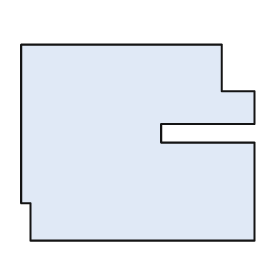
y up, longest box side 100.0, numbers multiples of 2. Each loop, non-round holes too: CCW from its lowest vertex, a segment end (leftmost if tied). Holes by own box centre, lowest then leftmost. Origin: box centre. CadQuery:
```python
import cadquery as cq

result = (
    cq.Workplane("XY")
    .moveTo(-46.0, -42.0)
    .lineTo(50.0, -42.0)
    .lineTo(50.0, 0.0)
    .lineTo(10.0, 0.0)
    .lineTo(10.0, 8.0)
    .lineTo(50.0, 8.0)
    .lineTo(50.0, 22.0)
    .lineTo(36.0, 22.0)
    .lineTo(36.0, 42.0)
    .lineTo(-50.0, 42.0)
    .lineTo(-50.0, -26.0)
    .lineTo(-46.0, -26.0)
    .close()
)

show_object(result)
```